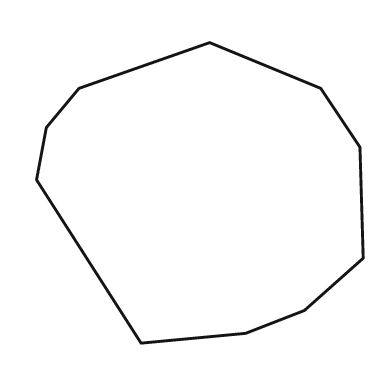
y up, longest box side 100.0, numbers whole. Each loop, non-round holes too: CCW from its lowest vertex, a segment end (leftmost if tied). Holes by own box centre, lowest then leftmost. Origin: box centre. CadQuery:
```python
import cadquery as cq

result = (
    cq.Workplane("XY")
    .moveTo(-18.0, -46.0)
    .lineTo(14.0, -43.0)
    .lineTo(32.0, -36.0)
    .lineTo(50.0, -20.0)
    .lineTo(49.0, 14.0)
    .lineTo(37.0, 32.0)
    .lineTo(3.0, 46.0)
    .lineTo(-37.0, 32.0)
    .lineTo(-47.0, 20.0)
    .lineTo(-50.0, 4.0)
    .close()
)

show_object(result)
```